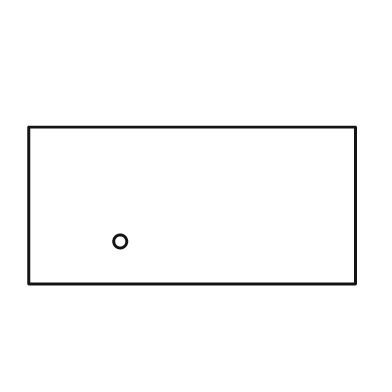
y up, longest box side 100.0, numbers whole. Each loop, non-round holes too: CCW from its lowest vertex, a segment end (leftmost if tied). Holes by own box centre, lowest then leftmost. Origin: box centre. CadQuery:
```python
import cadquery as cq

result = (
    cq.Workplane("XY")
    .moveTo(-50.0, -24.0)
    .lineTo(50.0, -24.0)
    .lineTo(50.0, 24.0)
    .lineTo(-50.0, 24.0)
    .close()
    .moveTo(-22.0, -11.0)
    .circle(2.0)
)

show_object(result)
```